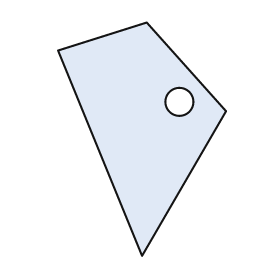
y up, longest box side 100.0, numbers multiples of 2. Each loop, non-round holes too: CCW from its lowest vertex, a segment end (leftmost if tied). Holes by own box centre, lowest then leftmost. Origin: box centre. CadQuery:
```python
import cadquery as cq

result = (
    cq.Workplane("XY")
    .moveTo(0.0, -50.0)
    .lineTo(36.0, 12.0)
    .lineTo(2.0, 50.0)
    .lineTo(-36.0, 38.0)
    .close()
    .moveTo(16.0, 16.0)
    .circle(6.0)
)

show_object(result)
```